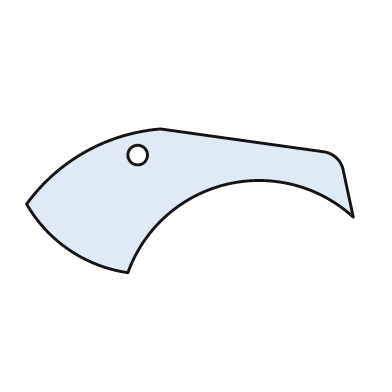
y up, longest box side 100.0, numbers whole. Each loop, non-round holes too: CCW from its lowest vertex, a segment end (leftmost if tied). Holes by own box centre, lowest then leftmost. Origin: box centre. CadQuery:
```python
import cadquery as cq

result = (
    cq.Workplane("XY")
    .moveTo(-19.0, -22.0)
    .threePointArc((11.0, 5.0), (50.0, -5.0))
    .lineTo(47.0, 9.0)
    .threePointArc((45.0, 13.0), (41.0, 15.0))
    .lineTo(-9.0, 22.0)
    .threePointArc((-32.0, 15.0), (-50.0, -1.0))
    .threePointArc((-37.0, -15.0), (-19.0, -22.0))
    .close()
    .moveTo(-16.0, 14.0)
    .circle(3.0)
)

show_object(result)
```